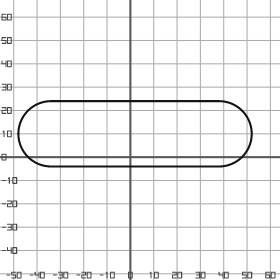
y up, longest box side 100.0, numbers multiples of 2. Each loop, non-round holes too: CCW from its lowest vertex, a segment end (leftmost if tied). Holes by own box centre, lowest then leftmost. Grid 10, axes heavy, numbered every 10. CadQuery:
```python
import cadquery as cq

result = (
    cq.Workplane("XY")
    .moveTo(-34.0, -4.0)
    .lineTo(38.0, -4.0)
    .threePointArc((52.0, 10.0), (38.0, 24.0))
    .lineTo(-34.0, 24.0)
    .threePointArc((-48.0, 10.0), (-34.0, -4.0))
    .close()
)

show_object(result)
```